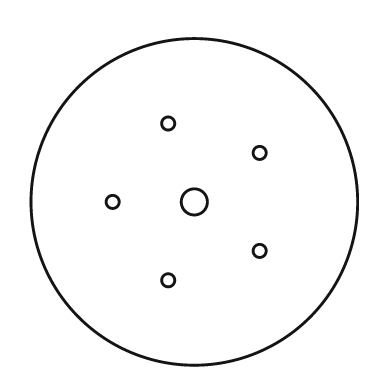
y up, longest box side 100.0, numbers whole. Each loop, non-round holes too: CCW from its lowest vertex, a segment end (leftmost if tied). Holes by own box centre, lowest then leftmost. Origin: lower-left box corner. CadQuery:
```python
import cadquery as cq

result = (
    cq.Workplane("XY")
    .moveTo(50.0, 50.0)
    .circle(50.0)
    .moveTo(42.0, 26.0)
    .circle(2.0)
    .moveTo(70.0, 35.0)
    .circle(2.0)
    .moveTo(25.0, 50.0)
    .circle(2.0)
    .moveTo(50.0, 50.0)
    .circle(4.0)
    .moveTo(70.0, 65.0)
    .circle(2.0)
    .moveTo(42.0, 74.0)
    .circle(2.0)
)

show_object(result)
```